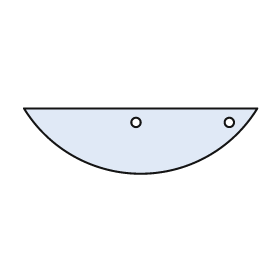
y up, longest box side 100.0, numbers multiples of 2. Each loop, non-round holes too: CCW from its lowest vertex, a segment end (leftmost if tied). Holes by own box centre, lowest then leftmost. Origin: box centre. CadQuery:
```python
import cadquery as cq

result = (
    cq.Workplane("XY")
    .moveTo(-50.0, 14.0)
    .threePointArc((0.0, -14.0), (50.0, 14.0))
    .close()
    .moveTo(-2.0, 8.0)
    .circle(2.0)
    .moveTo(38.0, 8.0)
    .circle(2.0)
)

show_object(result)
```